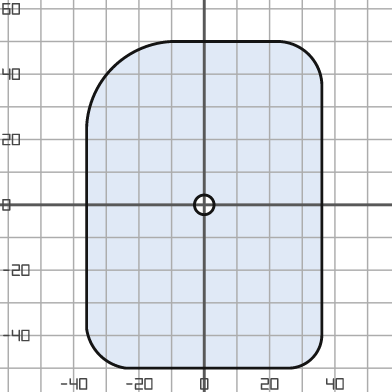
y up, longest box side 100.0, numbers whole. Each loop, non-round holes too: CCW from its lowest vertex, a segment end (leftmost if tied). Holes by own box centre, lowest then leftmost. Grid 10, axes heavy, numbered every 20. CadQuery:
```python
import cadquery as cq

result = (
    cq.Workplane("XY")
    .moveTo(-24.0, -50.0)
    .lineTo(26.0, -50.0)
    .threePointArc((33.0, -47.0), (36.0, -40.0))
    .lineTo(36.0, 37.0)
    .threePointArc((32.0, 46.0), (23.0, 50.0))
    .lineTo(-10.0, 50.0)
    .threePointArc((-28.0, 42.0), (-36.0, 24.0))
    .lineTo(-36.0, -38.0)
    .threePointArc((-32.0, -46.0), (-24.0, -50.0))
    .close()
    .moveTo(0.0, 0.0)
    .circle(3.0)
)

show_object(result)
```